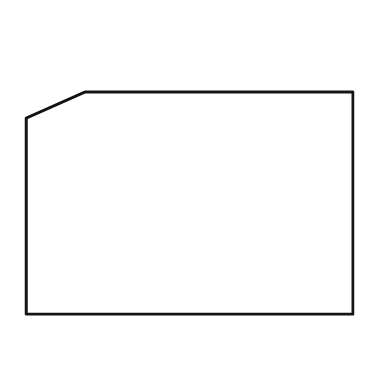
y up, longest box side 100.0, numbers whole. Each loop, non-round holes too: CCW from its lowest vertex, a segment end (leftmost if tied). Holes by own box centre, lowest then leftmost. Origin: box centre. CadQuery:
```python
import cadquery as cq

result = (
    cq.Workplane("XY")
    .moveTo(-50.0, -34.0)
    .lineTo(50.0, -34.0)
    .lineTo(50.0, 34.0)
    .lineTo(-32.0, 34.0)
    .lineTo(-50.0, 26.0)
    .close()
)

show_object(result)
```